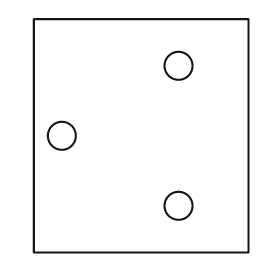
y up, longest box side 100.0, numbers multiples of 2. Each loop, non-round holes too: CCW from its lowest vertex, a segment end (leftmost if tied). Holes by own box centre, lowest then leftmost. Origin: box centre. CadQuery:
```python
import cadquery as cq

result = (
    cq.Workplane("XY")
    .moveTo(-46.0, -50.0)
    .lineTo(46.0, -50.0)
    .lineTo(46.0, 50.0)
    .lineTo(-46.0, 50.0)
    .close()
    .moveTo(16.0, -30.0)
    .circle(6.0)
    .moveTo(-34.0, 0.0)
    .circle(6.0)
    .moveTo(16.0, 30.0)
    .circle(6.0)
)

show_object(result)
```